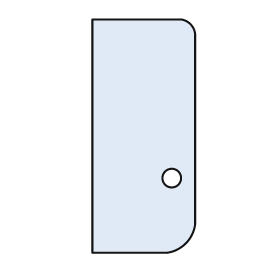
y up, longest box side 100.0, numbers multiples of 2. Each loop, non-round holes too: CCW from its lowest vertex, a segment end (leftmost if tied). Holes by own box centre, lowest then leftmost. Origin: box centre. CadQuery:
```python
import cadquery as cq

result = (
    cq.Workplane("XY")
    .moveTo(-22.0, -50.0)
    .lineTo(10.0, -50.0)
    .threePointArc((18.0, -46.0), (22.0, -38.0))
    .lineTo(22.0, 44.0)
    .threePointArc((20.0, 48.0), (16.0, 50.0))
    .lineTo(-22.0, 50.0)
    .close()
    .moveTo(12.0, -18.0)
    .circle(4.0)
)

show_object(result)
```